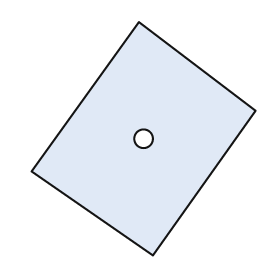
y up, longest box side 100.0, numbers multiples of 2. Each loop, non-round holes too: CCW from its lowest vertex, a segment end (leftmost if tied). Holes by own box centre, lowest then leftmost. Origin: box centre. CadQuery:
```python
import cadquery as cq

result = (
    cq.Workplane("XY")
    .moveTo(4.0, -50.0)
    .lineTo(48.0, 12.0)
    .lineTo(-2.0, 50.0)
    .lineTo(-48.0, -14.0)
    .close()
    .moveTo(0.0, 0.0)
    .circle(4.0)
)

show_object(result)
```